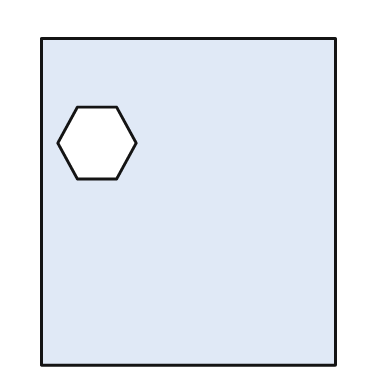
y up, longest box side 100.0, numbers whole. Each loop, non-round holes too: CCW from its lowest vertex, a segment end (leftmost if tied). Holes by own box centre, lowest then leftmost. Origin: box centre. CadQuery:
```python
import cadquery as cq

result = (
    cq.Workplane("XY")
    .moveTo(-45.0, -50.0)
    .lineTo(45.0, -50.0)
    .lineTo(45.0, 50.0)
    .lineTo(-45.0, 50.0)
    .close()
    .moveTo(-34.0, 7.0)
    .lineTo(-22.0, 7.0)
    .lineTo(-16.0, 18.0)
    .lineTo(-22.0, 29.0)
    .lineTo(-34.0, 29.0)
    .lineTo(-40.0, 18.0)
    .close()
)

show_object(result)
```